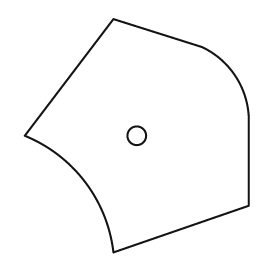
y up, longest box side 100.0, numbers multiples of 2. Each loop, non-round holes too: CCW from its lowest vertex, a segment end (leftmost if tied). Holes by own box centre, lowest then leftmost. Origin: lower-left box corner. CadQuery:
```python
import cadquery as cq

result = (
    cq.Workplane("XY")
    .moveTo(38.0, 0.0)
    .lineTo(96.0, 20.0)
    .lineTo(96.0, 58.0)
    .threePointArc((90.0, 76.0), (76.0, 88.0))
    .lineTo(38.0, 100.0)
    .lineTo(0.0, 50.0)
    .threePointArc((26.0, 30.0), (38.0, 0.0))
    .close()
    .moveTo(48.0, 50.0)
    .circle(4.0)
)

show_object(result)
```